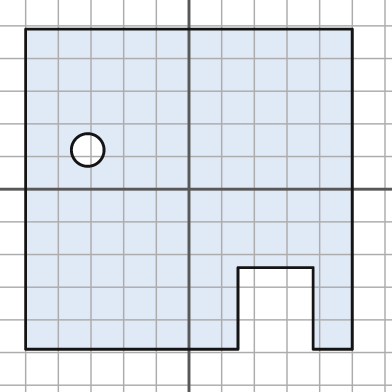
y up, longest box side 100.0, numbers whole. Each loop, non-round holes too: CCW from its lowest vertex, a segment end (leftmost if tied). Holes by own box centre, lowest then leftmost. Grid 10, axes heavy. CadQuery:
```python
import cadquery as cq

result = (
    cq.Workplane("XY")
    .moveTo(-50.0, -49.0)
    .lineTo(15.0, -49.0)
    .lineTo(15.0, -24.0)
    .lineTo(38.0, -24.0)
    .lineTo(38.0, -49.0)
    .lineTo(50.0, -49.0)
    .lineTo(50.0, 49.0)
    .lineTo(-50.0, 49.0)
    .close()
    .moveTo(-31.0, 12.0)
    .circle(5.0)
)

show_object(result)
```